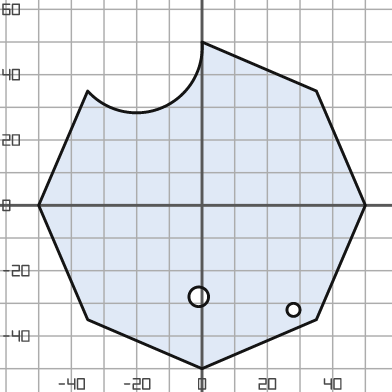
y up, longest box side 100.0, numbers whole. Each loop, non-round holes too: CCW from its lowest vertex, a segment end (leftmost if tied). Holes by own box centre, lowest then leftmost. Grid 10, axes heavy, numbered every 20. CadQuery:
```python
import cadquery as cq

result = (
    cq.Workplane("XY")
    .moveTo(0.0, -50.0)
    .lineTo(35.0, -35.0)
    .lineTo(50.0, 0.0)
    .lineTo(35.0, 35.0)
    .lineTo(0.0, 50.0)
    .threePointArc((-12.0, 30.0), (-35.0, 35.0))
    .lineTo(-50.0, 0.0)
    .lineTo(-35.0, -35.0)
    .close()
    .moveTo(28.0, -32.0)
    .circle(2.0)
    .moveTo(-1.0, -28.0)
    .circle(3.0)
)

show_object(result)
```